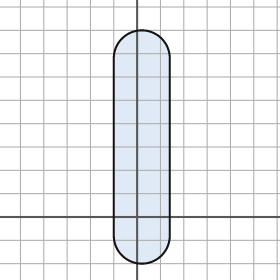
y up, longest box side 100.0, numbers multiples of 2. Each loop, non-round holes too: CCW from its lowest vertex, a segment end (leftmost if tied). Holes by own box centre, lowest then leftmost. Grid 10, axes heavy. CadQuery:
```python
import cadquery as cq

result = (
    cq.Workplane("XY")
    .moveTo(-10.0, -8.0)
    .threePointArc((2.0, -20.0), (14.0, -8.0))
    .lineTo(14.0, 68.0)
    .threePointArc((2.0, 80.0), (-10.0, 68.0))
    .close()
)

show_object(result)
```